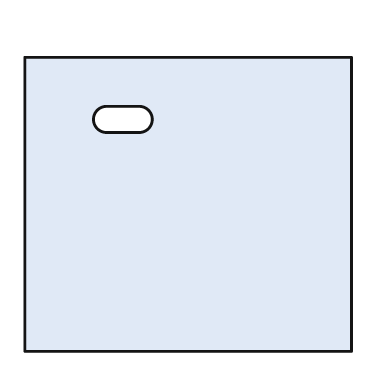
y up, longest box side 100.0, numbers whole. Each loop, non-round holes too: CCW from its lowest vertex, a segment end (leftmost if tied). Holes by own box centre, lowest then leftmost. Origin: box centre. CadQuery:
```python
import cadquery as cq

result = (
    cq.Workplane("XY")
    .moveTo(-50.0, -45.0)
    .lineTo(50.0, -45.0)
    .lineTo(50.0, 45.0)
    .lineTo(-50.0, 45.0)
    .close()
    .moveTo(-25.0, 22.0)
    .lineTo(-15.0, 22.0)
    .threePointArc((-11.0, 26.0), (-15.0, 30.0))
    .lineTo(-25.0, 30.0)
    .threePointArc((-29.0, 26.0), (-25.0, 22.0))
    .close()
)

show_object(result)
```